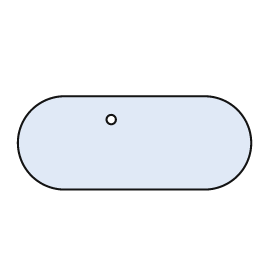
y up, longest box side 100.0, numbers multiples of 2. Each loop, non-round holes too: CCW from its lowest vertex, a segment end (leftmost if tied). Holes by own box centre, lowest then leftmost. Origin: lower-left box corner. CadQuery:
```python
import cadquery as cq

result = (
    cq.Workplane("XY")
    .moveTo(20.0, 0.0)
    .lineTo(80.0, 0.0)
    .threePointArc((100.0, 20.0), (80.0, 40.0))
    .lineTo(20.0, 40.0)
    .threePointArc((0.0, 20.0), (20.0, 0.0))
    .close()
    .moveTo(40.0, 30.0)
    .circle(2.0)
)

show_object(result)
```